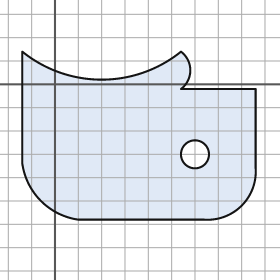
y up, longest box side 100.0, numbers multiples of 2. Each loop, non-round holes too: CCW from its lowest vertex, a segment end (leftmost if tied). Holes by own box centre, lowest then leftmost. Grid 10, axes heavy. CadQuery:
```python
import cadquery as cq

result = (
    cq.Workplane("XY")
    .moveTo(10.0, -58.0)
    .lineTo(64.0, -58.0)
    .threePointArc((80.0, -52.0), (86.0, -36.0))
    .lineTo(86.0, -2.0)
    .lineTo(54.0, -2.0)
    .threePointArc((58.0, 6.0), (54.0, 14.0))
    .threePointArc((20.0, 2.0), (-14.0, 14.0))
    .lineTo(-14.0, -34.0)
    .threePointArc((-6.0, -50.0), (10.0, -58.0))
    .close()
    .moveTo(60.0, -30.0)
    .circle(6.0)
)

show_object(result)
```